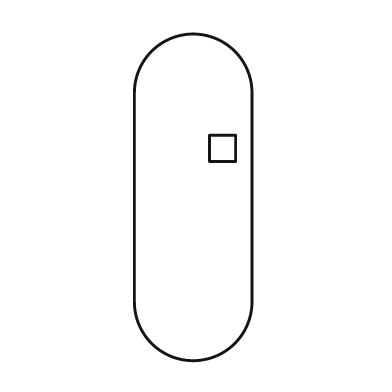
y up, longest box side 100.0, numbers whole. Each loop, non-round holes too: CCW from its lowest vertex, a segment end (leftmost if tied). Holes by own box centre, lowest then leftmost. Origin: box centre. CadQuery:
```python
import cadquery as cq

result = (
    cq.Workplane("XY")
    .moveTo(-18.0, -32.0)
    .threePointArc((0.0, -50.0), (18.0, -32.0))
    .lineTo(18.0, 32.0)
    .threePointArc((0.0, 50.0), (-18.0, 32.0))
    .close()
    .moveTo(5.0, 11.0)
    .lineTo(13.0, 11.0)
    .lineTo(13.0, 19.0)
    .lineTo(5.0, 19.0)
    .close()
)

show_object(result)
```